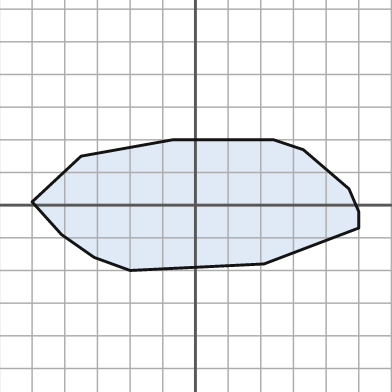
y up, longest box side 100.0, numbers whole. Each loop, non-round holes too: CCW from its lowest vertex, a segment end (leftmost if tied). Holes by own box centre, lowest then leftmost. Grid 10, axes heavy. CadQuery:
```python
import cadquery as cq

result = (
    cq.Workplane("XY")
    .moveTo(-20.0, -20.0)
    .lineTo(21.0, -18.0)
    .lineTo(50.0, -7.0)
    .lineTo(50.0, -2.0)
    .lineTo(47.0, 5.0)
    .lineTo(33.0, 17.0)
    .lineTo(24.0, 20.0)
    .lineTo(-7.0, 20.0)
    .lineTo(-35.0, 15.0)
    .lineTo(-50.0, 1.0)
    .lineTo(-41.0, -9.0)
    .lineTo(-31.0, -16.0)
    .close()
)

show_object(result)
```